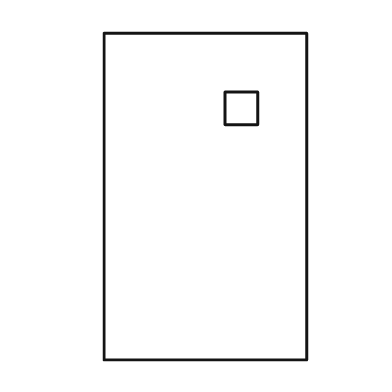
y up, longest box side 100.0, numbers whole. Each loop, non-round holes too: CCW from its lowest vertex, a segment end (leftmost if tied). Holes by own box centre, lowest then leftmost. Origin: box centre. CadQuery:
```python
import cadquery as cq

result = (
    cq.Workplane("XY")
    .moveTo(-31.0, -50.0)
    .lineTo(31.0, -50.0)
    .lineTo(31.0, 50.0)
    .lineTo(-31.0, 50.0)
    .close()
    .moveTo(6.0, 22.0)
    .lineTo(16.0, 22.0)
    .lineTo(16.0, 32.0)
    .lineTo(6.0, 32.0)
    .close()
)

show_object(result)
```